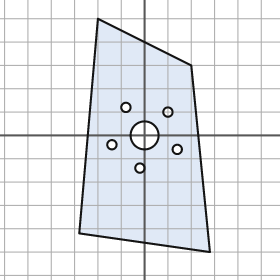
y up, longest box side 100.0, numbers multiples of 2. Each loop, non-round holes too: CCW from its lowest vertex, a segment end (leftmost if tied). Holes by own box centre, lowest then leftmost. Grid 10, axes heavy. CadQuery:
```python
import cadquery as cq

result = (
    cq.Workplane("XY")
    .moveTo(28.0, -50.0)
    .lineTo(20.0, 30.0)
    .lineTo(-20.0, 50.0)
    .lineTo(-28.0, -42.0)
    .close()
    .moveTo(-2.0, -14.0)
    .circle(2.0)
    .moveTo(14.0, -6.0)
    .circle(2.0)
    .moveTo(-14.0, -4.0)
    .circle(2.0)
    .moveTo(0.0, 0.0)
    .circle(6.0)
    .moveTo(10.0, 10.0)
    .circle(2.0)
    .moveTo(-8.0, 12.0)
    .circle(2.0)
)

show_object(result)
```